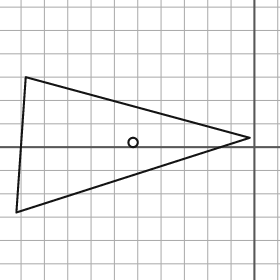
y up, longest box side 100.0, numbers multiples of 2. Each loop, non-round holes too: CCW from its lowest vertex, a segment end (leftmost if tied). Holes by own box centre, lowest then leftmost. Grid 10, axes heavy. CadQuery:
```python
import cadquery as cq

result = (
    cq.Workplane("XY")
    .moveTo(-102.0, -28.0)
    .lineTo(-2.0, 4.0)
    .lineTo(-98.0, 30.0)
    .close()
    .moveTo(-52.0, 2.0)
    .circle(2.0)
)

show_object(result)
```